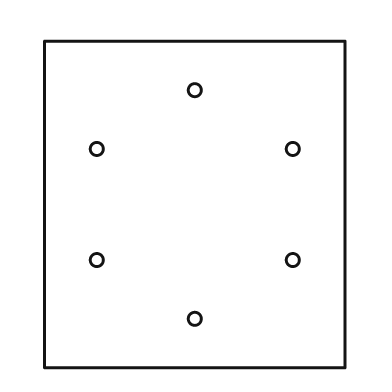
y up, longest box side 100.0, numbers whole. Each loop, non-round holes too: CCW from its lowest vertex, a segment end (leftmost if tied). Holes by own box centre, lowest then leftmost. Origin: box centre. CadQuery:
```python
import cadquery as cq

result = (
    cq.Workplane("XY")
    .moveTo(-46.0, -50.0)
    .lineTo(46.0, -50.0)
    .lineTo(46.0, 50.0)
    .lineTo(-46.0, 50.0)
    .close()
    .moveTo(0.0, -35.0)
    .circle(2.0)
    .moveTo(-30.0, -17.0)
    .circle(2.0)
    .moveTo(30.0, -17.0)
    .circle(2.0)
    .moveTo(-30.0, 17.0)
    .circle(2.0)
    .moveTo(30.0, 17.0)
    .circle(2.0)
    .moveTo(0.0, 35.0)
    .circle(2.0)
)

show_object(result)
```